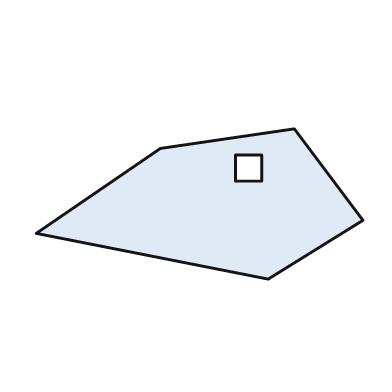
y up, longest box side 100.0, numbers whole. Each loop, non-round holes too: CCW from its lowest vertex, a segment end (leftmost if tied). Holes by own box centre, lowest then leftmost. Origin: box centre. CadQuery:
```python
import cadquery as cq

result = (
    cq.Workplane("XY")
    .moveTo(21.0, -23.0)
    .lineTo(50.0, -5.0)
    .lineTo(29.0, 23.0)
    .lineTo(-12.0, 17.0)
    .lineTo(-50.0, -9.0)
    .close()
    .moveTo(11.0, 7.0)
    .lineTo(19.0, 7.0)
    .lineTo(19.0, 15.0)
    .lineTo(11.0, 15.0)
    .close()
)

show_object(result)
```